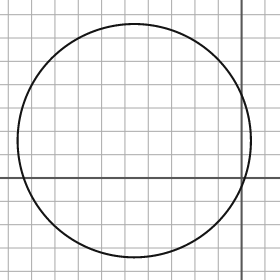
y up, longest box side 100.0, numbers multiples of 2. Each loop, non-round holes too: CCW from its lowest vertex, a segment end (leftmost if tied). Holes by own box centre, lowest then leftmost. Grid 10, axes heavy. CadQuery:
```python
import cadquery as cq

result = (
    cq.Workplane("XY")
    .moveTo(-46.0, 16.0)
    .circle(50.0)
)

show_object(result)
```